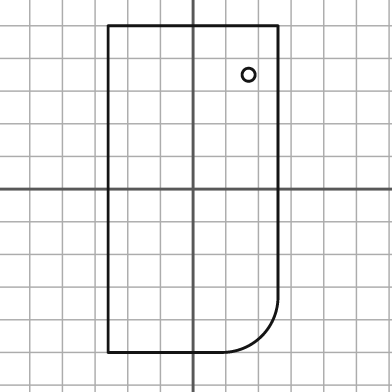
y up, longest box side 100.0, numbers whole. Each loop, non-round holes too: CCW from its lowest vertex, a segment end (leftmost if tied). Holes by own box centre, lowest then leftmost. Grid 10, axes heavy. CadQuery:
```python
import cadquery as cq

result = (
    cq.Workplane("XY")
    .moveTo(-26.0, -50.0)
    .lineTo(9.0, -50.0)
    .threePointArc((21.0, -45.0), (26.0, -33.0))
    .lineTo(26.0, 50.0)
    .lineTo(-26.0, 50.0)
    .close()
    .moveTo(17.0, 35.0)
    .circle(2.0)
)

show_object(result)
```